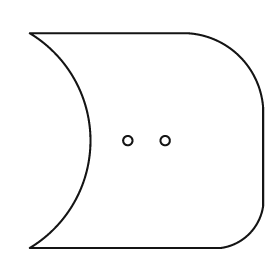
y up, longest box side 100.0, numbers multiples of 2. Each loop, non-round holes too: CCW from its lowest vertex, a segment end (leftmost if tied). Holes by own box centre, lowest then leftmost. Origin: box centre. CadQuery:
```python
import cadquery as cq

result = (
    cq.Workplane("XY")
    .moveTo(-50.0, -46.0)
    .lineTo(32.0, -46.0)
    .threePointArc((44.0, -40.0), (50.0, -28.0))
    .lineTo(50.0, 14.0)
    .threePointArc((40.0, 36.0), (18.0, 46.0))
    .lineTo(-50.0, 46.0)
    .threePointArc((-24.0, 0.0), (-50.0, -46.0))
    .close()
    .moveTo(-8.0, 0.0)
    .circle(2.0)
    .moveTo(8.0, 0.0)
    .circle(2.0)
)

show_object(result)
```